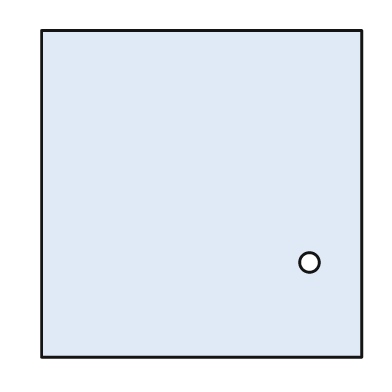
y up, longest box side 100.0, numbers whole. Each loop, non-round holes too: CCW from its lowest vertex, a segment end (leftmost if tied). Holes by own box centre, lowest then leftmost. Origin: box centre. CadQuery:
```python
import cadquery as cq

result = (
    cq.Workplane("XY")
    .moveTo(-49.0, -50.0)
    .lineTo(49.0, -50.0)
    .lineTo(49.0, 50.0)
    .lineTo(-49.0, 50.0)
    .close()
    .moveTo(33.0, -21.0)
    .circle(3.0)
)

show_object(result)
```